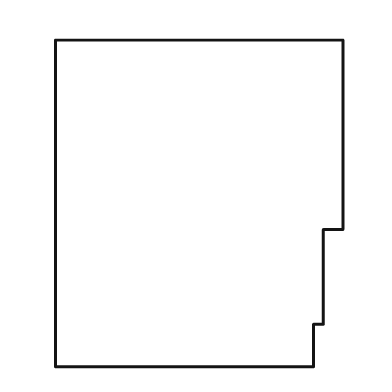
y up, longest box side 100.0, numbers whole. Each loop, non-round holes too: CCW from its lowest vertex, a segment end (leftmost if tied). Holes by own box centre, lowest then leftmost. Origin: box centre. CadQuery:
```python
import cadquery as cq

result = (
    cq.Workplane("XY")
    .moveTo(-44.0, -50.0)
    .lineTo(35.0, -50.0)
    .lineTo(35.0, -37.0)
    .lineTo(38.0, -37.0)
    .lineTo(38.0, -8.0)
    .lineTo(44.0, -8.0)
    .lineTo(44.0, 50.0)
    .lineTo(-44.0, 50.0)
    .close()
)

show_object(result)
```